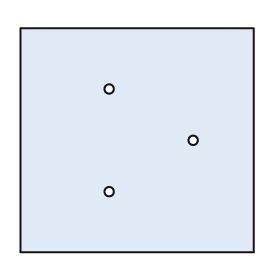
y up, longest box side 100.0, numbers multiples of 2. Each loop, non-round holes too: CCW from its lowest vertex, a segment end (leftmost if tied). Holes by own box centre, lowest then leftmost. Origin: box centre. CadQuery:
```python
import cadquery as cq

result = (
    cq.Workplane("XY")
    .moveTo(-50.0, -48.0)
    .lineTo(50.0, -48.0)
    .lineTo(50.0, 48.0)
    .lineTo(-50.0, 48.0)
    .close()
    .moveTo(-12.0, -22.0)
    .circle(2.0)
    .moveTo(24.0, 0.0)
    .circle(2.0)
    .moveTo(-12.0, 22.0)
    .circle(2.0)
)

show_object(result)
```